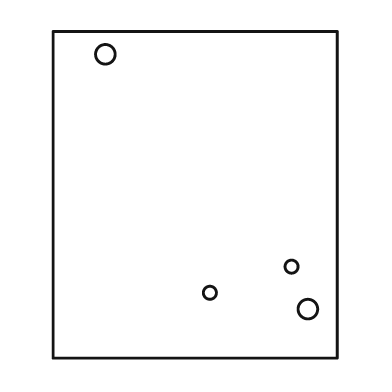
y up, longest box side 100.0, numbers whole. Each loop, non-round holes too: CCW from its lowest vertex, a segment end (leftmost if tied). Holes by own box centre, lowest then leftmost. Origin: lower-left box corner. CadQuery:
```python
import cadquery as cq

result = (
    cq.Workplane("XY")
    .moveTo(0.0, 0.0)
    .lineTo(87.0, 0.0)
    .lineTo(87.0, 100.0)
    .lineTo(0.0, 100.0)
    .close()
    .moveTo(78.0, 15.0)
    .circle(3.0)
    .moveTo(48.0, 20.0)
    .circle(2.0)
    .moveTo(73.0, 28.0)
    .circle(2.0)
    .moveTo(16.0, 93.0)
    .circle(3.0)
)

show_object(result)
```